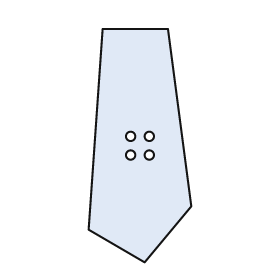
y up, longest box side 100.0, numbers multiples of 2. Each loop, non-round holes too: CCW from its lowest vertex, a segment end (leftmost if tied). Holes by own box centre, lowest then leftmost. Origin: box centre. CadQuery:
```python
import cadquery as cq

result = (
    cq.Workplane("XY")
    .moveTo(2.0, -50.0)
    .lineTo(22.0, -26.0)
    .lineTo(12.0, 50.0)
    .lineTo(-16.0, 50.0)
    .lineTo(-22.0, -36.0)
    .close()
    .moveTo(-4.0, -4.0)
    .circle(2.0)
    .moveTo(4.0, -4.0)
    .circle(2.0)
    .moveTo(-4.0, 4.0)
    .circle(2.0)
    .moveTo(4.0, 4.0)
    .circle(2.0)
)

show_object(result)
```